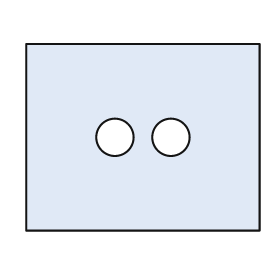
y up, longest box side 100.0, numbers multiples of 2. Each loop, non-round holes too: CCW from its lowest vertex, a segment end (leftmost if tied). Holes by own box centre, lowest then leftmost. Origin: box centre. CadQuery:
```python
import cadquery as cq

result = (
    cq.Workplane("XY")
    .moveTo(-50.0, -40.0)
    .lineTo(50.0, -40.0)
    .lineTo(50.0, 40.0)
    .lineTo(-50.0, 40.0)
    .close()
    .moveTo(-12.0, 0.0)
    .circle(8.0)
    .moveTo(12.0, 0.0)
    .circle(8.0)
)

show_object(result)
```